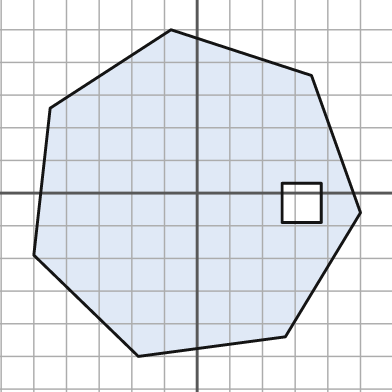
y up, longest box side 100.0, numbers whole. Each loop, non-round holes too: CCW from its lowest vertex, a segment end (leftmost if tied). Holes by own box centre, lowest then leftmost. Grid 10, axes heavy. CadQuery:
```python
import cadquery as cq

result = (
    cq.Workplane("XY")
    .moveTo(-18.0, -50.0)
    .lineTo(27.0, -44.0)
    .lineTo(50.0, -6.0)
    .lineTo(35.0, 36.0)
    .lineTo(-8.0, 50.0)
    .lineTo(-45.0, 26.0)
    .lineTo(-50.0, -19.0)
    .close()
    .moveTo(26.0, -9.0)
    .lineTo(38.0, -9.0)
    .lineTo(38.0, 3.0)
    .lineTo(26.0, 3.0)
    .close()
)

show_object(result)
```